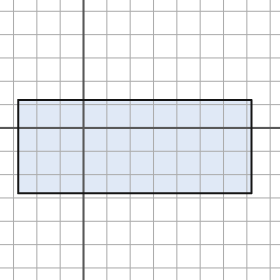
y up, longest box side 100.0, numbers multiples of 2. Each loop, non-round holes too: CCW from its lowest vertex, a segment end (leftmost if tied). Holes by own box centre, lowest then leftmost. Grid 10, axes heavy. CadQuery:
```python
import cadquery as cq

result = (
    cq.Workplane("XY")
    .moveTo(-28.0, -28.0)
    .lineTo(72.0, -28.0)
    .lineTo(72.0, 12.0)
    .lineTo(-28.0, 12.0)
    .close()
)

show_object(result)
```